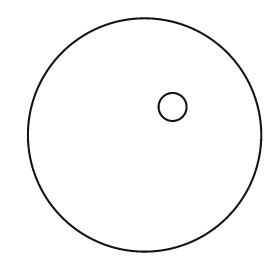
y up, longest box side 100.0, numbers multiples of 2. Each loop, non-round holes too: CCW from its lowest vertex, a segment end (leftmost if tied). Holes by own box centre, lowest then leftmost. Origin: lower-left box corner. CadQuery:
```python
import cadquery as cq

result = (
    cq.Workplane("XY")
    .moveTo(50.0, 50.0)
    .circle(50.0)
    .moveTo(62.0, 62.0)
    .circle(6.0)
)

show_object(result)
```